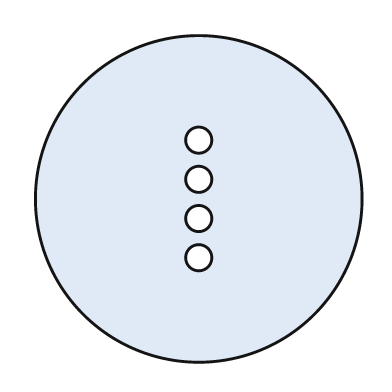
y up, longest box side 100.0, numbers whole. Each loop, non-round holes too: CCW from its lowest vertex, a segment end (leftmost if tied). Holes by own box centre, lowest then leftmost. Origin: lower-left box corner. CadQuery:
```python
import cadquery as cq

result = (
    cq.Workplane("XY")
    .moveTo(50.0, 50.0)
    .circle(50.0)
    .moveTo(50.0, 32.0)
    .circle(4.0)
    .moveTo(50.0, 44.0)
    .circle(4.0)
    .moveTo(50.0, 56.0)
    .circle(4.0)
    .moveTo(50.0, 68.0)
    .circle(4.0)
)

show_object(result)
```